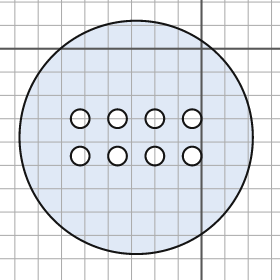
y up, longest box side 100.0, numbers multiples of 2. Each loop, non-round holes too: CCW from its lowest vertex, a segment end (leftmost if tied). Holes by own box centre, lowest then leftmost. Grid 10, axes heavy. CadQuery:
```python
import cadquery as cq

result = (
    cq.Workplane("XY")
    .moveTo(-28.0, -38.0)
    .circle(50.0)
    .moveTo(-52.0, -46.0)
    .circle(4.0)
    .moveTo(-36.0, -46.0)
    .circle(4.0)
    .moveTo(-20.0, -46.0)
    .circle(4.0)
    .moveTo(-4.0, -46.0)
    .circle(4.0)
    .moveTo(-52.0, -30.0)
    .circle(4.0)
    .moveTo(-36.0, -30.0)
    .circle(4.0)
    .moveTo(-20.0, -30.0)
    .circle(4.0)
    .moveTo(-4.0, -30.0)
    .circle(4.0)
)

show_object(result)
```